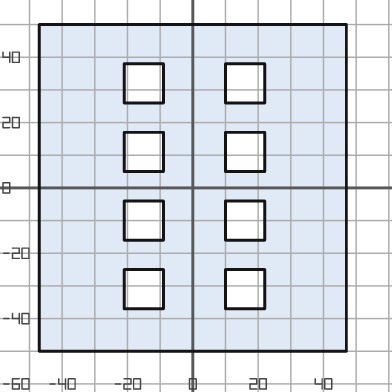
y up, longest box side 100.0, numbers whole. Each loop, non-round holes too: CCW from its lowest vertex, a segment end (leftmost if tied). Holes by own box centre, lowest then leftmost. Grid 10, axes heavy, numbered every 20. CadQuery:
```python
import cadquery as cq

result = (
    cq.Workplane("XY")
    .moveTo(-47.0, -50.0)
    .lineTo(47.0, -50.0)
    .lineTo(47.0, 50.0)
    .lineTo(-47.0, 50.0)
    .close()
    .moveTo(-21.0, -37.0)
    .lineTo(-9.0, -37.0)
    .lineTo(-9.0, -25.0)
    .lineTo(-21.0, -25.0)
    .close()
    .moveTo(10.0, -37.0)
    .lineTo(22.0, -37.0)
    .lineTo(22.0, -25.0)
    .lineTo(10.0, -25.0)
    .close()
    .moveTo(-21.0, -16.0)
    .lineTo(-9.0, -16.0)
    .lineTo(-9.0, -4.0)
    .lineTo(-21.0, -4.0)
    .close()
    .moveTo(10.0, -16.0)
    .lineTo(22.0, -16.0)
    .lineTo(22.0, -4.0)
    .lineTo(10.0, -4.0)
    .close()
    .moveTo(-21.0, 5.0)
    .lineTo(-9.0, 5.0)
    .lineTo(-9.0, 17.0)
    .lineTo(-21.0, 17.0)
    .close()
    .moveTo(10.0, 5.0)
    .lineTo(22.0, 5.0)
    .lineTo(22.0, 17.0)
    .lineTo(10.0, 17.0)
    .close()
    .moveTo(-21.0, 26.0)
    .lineTo(-9.0, 26.0)
    .lineTo(-9.0, 38.0)
    .lineTo(-21.0, 38.0)
    .close()
    .moveTo(10.0, 26.0)
    .lineTo(22.0, 26.0)
    .lineTo(22.0, 38.0)
    .lineTo(10.0, 38.0)
    .close()
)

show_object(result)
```